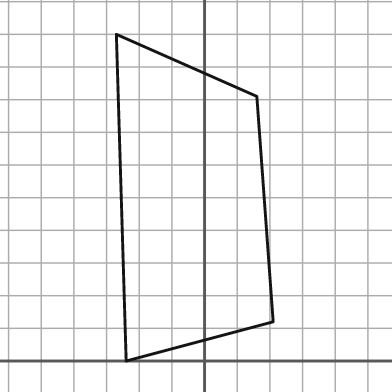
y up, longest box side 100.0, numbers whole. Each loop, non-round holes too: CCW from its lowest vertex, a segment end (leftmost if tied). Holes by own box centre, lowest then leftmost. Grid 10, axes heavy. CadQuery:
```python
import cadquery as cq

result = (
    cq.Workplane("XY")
    .moveTo(-24.0, 0.0)
    .lineTo(21.0, 12.0)
    .lineTo(16.0, 81.0)
    .lineTo(-27.0, 100.0)
    .close()
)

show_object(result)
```